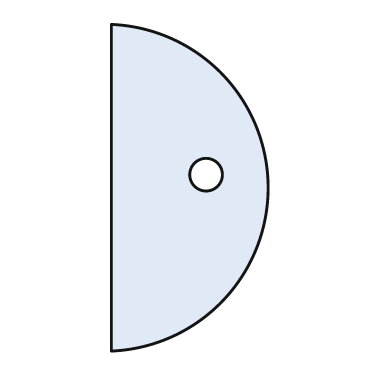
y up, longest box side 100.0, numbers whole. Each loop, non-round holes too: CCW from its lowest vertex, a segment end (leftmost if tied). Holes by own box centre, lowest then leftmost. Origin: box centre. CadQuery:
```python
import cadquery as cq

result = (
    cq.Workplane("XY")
    .moveTo(-24.0, -50.0)
    .threePointArc((24.0, 0.0), (-24.0, 50.0))
    .close()
    .moveTo(5.0, 4.0)
    .circle(5.0)
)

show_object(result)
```